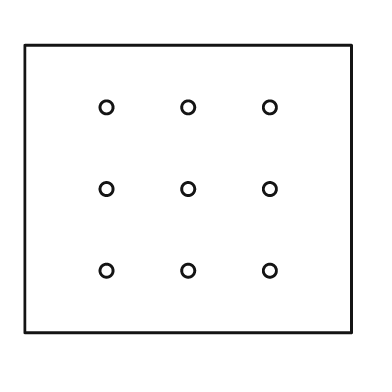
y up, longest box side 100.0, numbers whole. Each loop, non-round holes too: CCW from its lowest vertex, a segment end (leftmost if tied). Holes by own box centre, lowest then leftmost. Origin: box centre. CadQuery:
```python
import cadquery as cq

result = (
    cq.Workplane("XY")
    .moveTo(-50.0, -44.0)
    .lineTo(50.0, -44.0)
    .lineTo(50.0, 44.0)
    .lineTo(-50.0, 44.0)
    .close()
    .moveTo(-25.0, -25.0)
    .circle(2.0)
    .moveTo(0.0, -25.0)
    .circle(2.0)
    .moveTo(25.0, -25.0)
    .circle(2.0)
    .moveTo(-25.0, 0.0)
    .circle(2.0)
    .moveTo(0.0, 0.0)
    .circle(2.0)
    .moveTo(25.0, 0.0)
    .circle(2.0)
    .moveTo(-25.0, 25.0)
    .circle(2.0)
    .moveTo(0.0, 25.0)
    .circle(2.0)
    .moveTo(25.0, 25.0)
    .circle(2.0)
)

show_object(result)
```